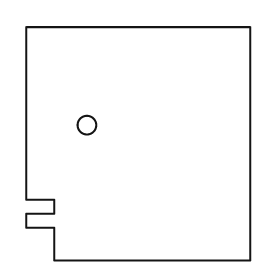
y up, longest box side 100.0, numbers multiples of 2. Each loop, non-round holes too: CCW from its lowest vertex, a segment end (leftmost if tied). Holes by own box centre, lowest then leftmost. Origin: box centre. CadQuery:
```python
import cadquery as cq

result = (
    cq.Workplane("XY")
    .moveTo(-36.0, -50.0)
    .lineTo(48.0, -50.0)
    .lineTo(48.0, 50.0)
    .lineTo(-48.0, 50.0)
    .lineTo(-48.0, -24.0)
    .lineTo(-36.0, -24.0)
    .lineTo(-36.0, -30.0)
    .lineTo(-48.0, -30.0)
    .lineTo(-48.0, -36.0)
    .lineTo(-36.0, -36.0)
    .close()
    .moveTo(-22.0, 8.0)
    .circle(4.0)
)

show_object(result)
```